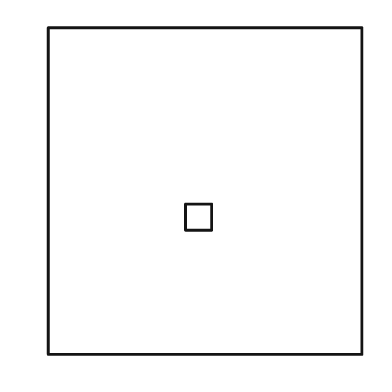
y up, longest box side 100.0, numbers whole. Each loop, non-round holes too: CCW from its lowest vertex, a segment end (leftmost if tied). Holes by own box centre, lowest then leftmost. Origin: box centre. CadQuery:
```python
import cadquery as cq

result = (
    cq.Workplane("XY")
    .moveTo(-48.0, -50.0)
    .lineTo(48.0, -50.0)
    .lineTo(48.0, 50.0)
    .lineTo(-48.0, 50.0)
    .close()
    .moveTo(-6.0, -12.0)
    .lineTo(2.0, -12.0)
    .lineTo(2.0, -4.0)
    .lineTo(-6.0, -4.0)
    .close()
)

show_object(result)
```